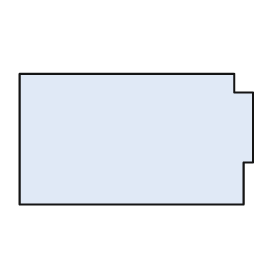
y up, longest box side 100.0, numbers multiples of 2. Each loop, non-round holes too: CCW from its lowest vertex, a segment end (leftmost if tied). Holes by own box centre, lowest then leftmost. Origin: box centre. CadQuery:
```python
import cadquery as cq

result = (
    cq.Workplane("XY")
    .moveTo(-50.0, -28.0)
    .lineTo(46.0, -28.0)
    .lineTo(46.0, -10.0)
    .lineTo(50.0, -10.0)
    .lineTo(50.0, 20.0)
    .lineTo(42.0, 20.0)
    .lineTo(42.0, 28.0)
    .lineTo(-50.0, 28.0)
    .close()
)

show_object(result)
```